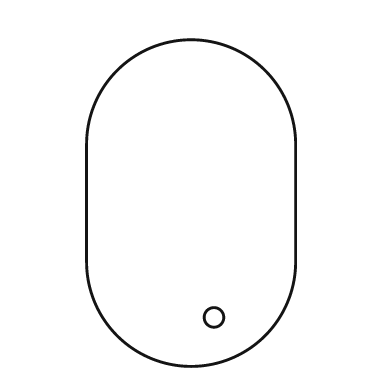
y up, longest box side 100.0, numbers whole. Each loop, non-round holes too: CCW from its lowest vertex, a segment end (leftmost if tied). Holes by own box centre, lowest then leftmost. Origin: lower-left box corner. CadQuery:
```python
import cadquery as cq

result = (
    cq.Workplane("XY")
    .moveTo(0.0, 32.0)
    .threePointArc((32.0, 0.0), (64.0, 32.0))
    .lineTo(64.0, 68.0)
    .threePointArc((32.0, 100.0), (0.0, 68.0))
    .close()
    .moveTo(39.0, 15.0)
    .circle(3.0)
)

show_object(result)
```